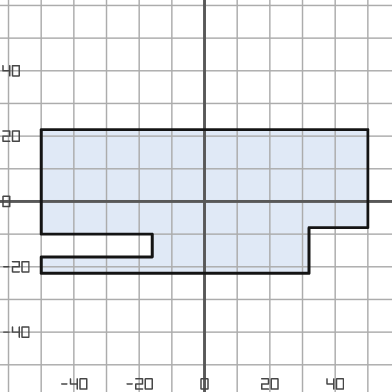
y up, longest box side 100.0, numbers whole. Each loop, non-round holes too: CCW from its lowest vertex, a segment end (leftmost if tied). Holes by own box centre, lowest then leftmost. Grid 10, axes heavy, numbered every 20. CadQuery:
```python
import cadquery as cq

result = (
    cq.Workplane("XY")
    .moveTo(-50.0, -22.0)
    .lineTo(32.0, -22.0)
    .lineTo(32.0, -8.0)
    .lineTo(50.0, -8.0)
    .lineTo(50.0, 22.0)
    .lineTo(-50.0, 22.0)
    .lineTo(-50.0, -10.0)
    .lineTo(-16.0, -10.0)
    .lineTo(-16.0, -17.0)
    .lineTo(-50.0, -17.0)
    .close()
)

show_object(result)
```